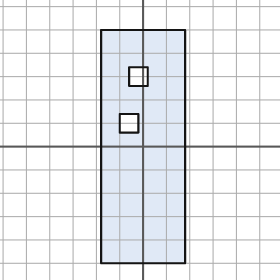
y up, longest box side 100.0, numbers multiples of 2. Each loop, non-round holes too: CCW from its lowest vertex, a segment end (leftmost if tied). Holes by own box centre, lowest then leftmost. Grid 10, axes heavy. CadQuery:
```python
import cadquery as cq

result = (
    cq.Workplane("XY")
    .moveTo(-18.0, -50.0)
    .lineTo(18.0, -50.0)
    .lineTo(18.0, 50.0)
    .lineTo(-18.0, 50.0)
    .close()
    .moveTo(-10.0, 6.0)
    .lineTo(-2.0, 6.0)
    .lineTo(-2.0, 14.0)
    .lineTo(-10.0, 14.0)
    .close()
    .moveTo(-6.0, 26.0)
    .lineTo(2.0, 26.0)
    .lineTo(2.0, 34.0)
    .lineTo(-6.0, 34.0)
    .close()
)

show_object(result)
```